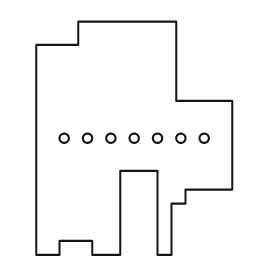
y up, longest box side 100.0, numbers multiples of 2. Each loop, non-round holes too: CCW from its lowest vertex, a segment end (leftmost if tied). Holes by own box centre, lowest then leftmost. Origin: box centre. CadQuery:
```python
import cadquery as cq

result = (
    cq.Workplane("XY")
    .moveTo(-42.0, -50.0)
    .lineTo(-32.0, -50.0)
    .lineTo(-32.0, -44.0)
    .lineTo(-18.0, -44.0)
    .lineTo(-18.0, -50.0)
    .lineTo(-6.0, -50.0)
    .lineTo(-6.0, -14.0)
    .lineTo(10.0, -14.0)
    .lineTo(10.0, -50.0)
    .lineTo(16.0, -50.0)
    .lineTo(16.0, -28.0)
    .lineTo(22.0, -28.0)
    .lineTo(22.0, -22.0)
    .lineTo(42.0, -22.0)
    .lineTo(42.0, 16.0)
    .lineTo(18.0, 16.0)
    .lineTo(18.0, 50.0)
    .lineTo(-24.0, 50.0)
    .lineTo(-24.0, 40.0)
    .lineTo(-42.0, 40.0)
    .close()
    .moveTo(-30.0, 0.0)
    .circle(2.0)
    .moveTo(-20.0, 0.0)
    .circle(2.0)
    .moveTo(-10.0, 0.0)
    .circle(2.0)
    .moveTo(0.0, 0.0)
    .circle(2.0)
    .moveTo(10.0, 0.0)
    .circle(2.0)
    .moveTo(20.0, 0.0)
    .circle(2.0)
    .moveTo(30.0, 0.0)
    .circle(2.0)
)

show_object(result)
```